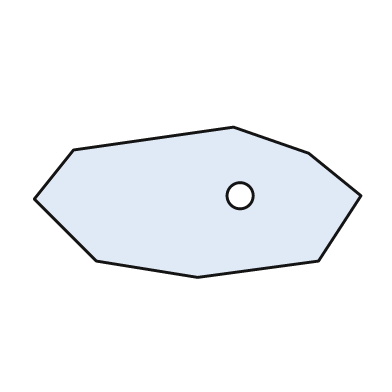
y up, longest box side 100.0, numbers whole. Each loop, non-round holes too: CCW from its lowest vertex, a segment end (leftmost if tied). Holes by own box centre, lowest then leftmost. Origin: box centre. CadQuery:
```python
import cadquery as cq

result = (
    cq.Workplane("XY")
    .moveTo(0.0, -23.0)
    .lineTo(37.0, -18.0)
    .lineTo(50.0, 2.0)
    .lineTo(34.0, 15.0)
    .lineTo(11.0, 23.0)
    .lineTo(-38.0, 16.0)
    .lineTo(-50.0, 1.0)
    .lineTo(-31.0, -18.0)
    .close()
    .moveTo(13.0, 2.0)
    .circle(4.0)
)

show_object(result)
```